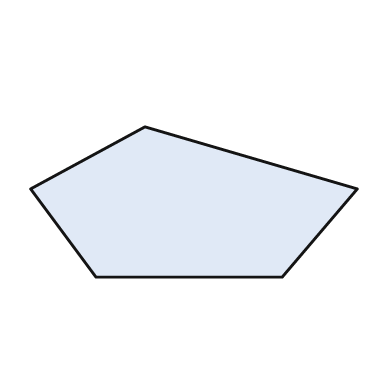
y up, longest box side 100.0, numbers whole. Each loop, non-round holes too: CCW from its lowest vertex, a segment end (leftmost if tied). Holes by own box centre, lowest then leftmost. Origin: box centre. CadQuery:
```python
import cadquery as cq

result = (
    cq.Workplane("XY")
    .moveTo(-30.0, -23.0)
    .lineTo(27.0, -23.0)
    .lineTo(50.0, 4.0)
    .lineTo(-15.0, 23.0)
    .lineTo(-50.0, 4.0)
    .close()
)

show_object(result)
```